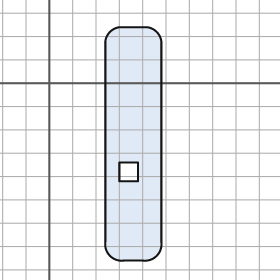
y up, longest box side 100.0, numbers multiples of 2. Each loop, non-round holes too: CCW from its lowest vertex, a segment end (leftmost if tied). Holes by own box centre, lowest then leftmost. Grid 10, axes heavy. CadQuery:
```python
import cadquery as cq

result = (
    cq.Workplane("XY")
    .moveTo(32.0, -76.0)
    .lineTo(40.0, -76.0)
    .threePointArc((46.0, -74.0), (48.0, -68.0))
    .lineTo(48.0, 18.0)
    .threePointArc((46.0, 22.0), (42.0, 24.0))
    .lineTo(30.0, 24.0)
    .threePointArc((26.0, 22.0), (24.0, 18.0))
    .lineTo(24.0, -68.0)
    .threePointArc((26.0, -74.0), (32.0, -76.0))
    .close()
    .moveTo(30.0, -42.0)
    .lineTo(38.0, -42.0)
    .lineTo(38.0, -34.0)
    .lineTo(30.0, -34.0)
    .close()
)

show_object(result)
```